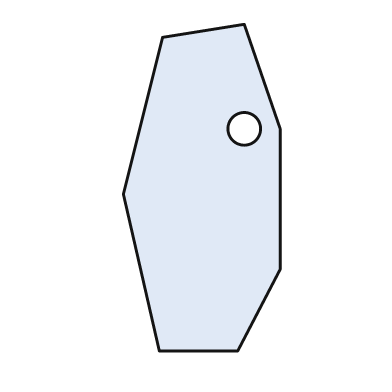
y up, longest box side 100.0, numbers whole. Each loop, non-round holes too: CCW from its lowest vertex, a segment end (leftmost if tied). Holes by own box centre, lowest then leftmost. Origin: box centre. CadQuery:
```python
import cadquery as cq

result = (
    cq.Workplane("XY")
    .moveTo(-13.0, -50.0)
    .lineTo(11.0, -50.0)
    .lineTo(24.0, -25.0)
    .lineTo(24.0, 18.0)
    .lineTo(13.0, 50.0)
    .lineTo(-12.0, 46.0)
    .lineTo(-24.0, -2.0)
    .close()
    .moveTo(13.0, 18.0)
    .circle(5.0)
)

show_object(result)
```